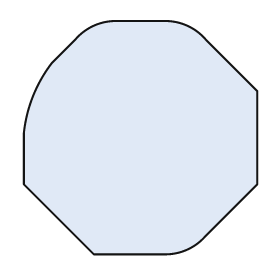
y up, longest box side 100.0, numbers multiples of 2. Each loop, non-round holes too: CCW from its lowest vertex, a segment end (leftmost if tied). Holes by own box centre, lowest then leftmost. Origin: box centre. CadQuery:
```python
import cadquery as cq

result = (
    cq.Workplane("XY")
    .moveTo(-20.0, -50.0)
    .lineTo(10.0, -50.0)
    .threePointArc((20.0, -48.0), (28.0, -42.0))
    .lineTo(50.0, -20.0)
    .lineTo(50.0, 20.0)
    .lineTo(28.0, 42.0)
    .threePointArc((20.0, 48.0), (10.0, 50.0))
    .lineTo(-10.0, 50.0)
    .threePointArc((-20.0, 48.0), (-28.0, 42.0))
    .lineTo(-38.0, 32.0)
    .threePointArc((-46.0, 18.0), (-50.0, 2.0))
    .lineTo(-50.0, -20.0)
    .close()
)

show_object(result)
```